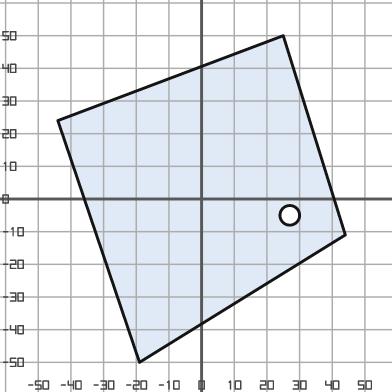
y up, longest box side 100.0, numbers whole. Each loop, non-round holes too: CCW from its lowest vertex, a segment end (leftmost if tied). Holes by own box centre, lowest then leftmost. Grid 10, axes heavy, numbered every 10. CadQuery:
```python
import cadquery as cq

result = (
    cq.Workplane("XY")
    .moveTo(-19.0, -50.0)
    .lineTo(44.0, -11.0)
    .lineTo(25.0, 50.0)
    .lineTo(-44.0, 24.0)
    .close()
    .moveTo(27.0, -5.0)
    .circle(3.0)
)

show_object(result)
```